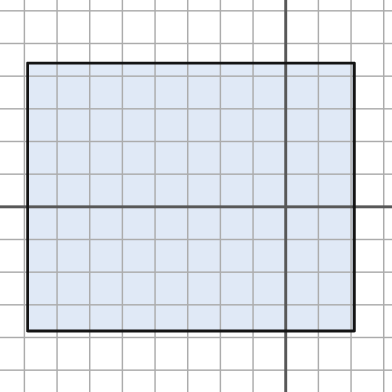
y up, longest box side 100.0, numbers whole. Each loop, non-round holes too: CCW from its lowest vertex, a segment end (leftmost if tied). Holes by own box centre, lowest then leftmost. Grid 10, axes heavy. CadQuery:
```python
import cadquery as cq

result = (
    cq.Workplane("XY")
    .moveTo(-79.0, -38.0)
    .lineTo(21.0, -38.0)
    .lineTo(21.0, 44.0)
    .lineTo(-79.0, 44.0)
    .close()
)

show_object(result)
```